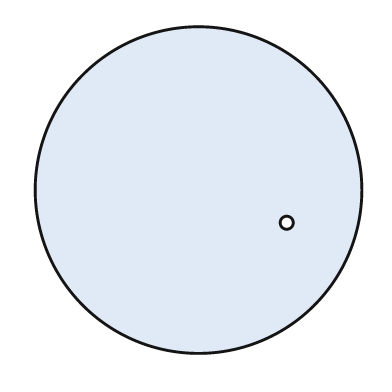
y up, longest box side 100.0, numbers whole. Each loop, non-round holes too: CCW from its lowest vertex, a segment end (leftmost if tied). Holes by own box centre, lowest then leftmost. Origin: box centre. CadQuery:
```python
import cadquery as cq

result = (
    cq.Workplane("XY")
    .moveTo(0.0, 0.0)
    .circle(50.0)
    .moveTo(27.0, -10.0)
    .circle(2.0)
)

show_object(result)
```